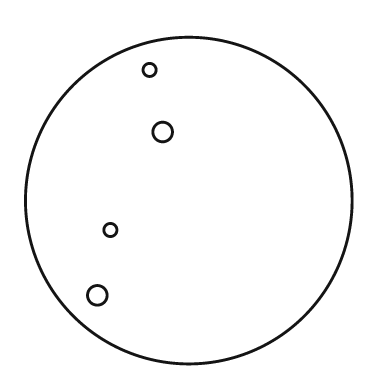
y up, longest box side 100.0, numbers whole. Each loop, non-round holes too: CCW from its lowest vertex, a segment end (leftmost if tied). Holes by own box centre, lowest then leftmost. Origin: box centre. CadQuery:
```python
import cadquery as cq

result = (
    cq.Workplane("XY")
    .moveTo(0.0, 0.0)
    .circle(50.0)
    .moveTo(-28.0, -29.0)
    .circle(3.0)
    .moveTo(-24.0, -9.0)
    .circle(2.0)
    .moveTo(-8.0, 21.0)
    .circle(3.0)
    .moveTo(-12.0, 40.0)
    .circle(2.0)
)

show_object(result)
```